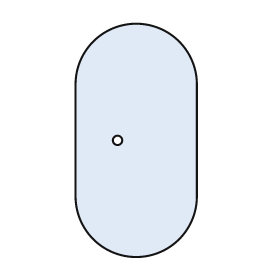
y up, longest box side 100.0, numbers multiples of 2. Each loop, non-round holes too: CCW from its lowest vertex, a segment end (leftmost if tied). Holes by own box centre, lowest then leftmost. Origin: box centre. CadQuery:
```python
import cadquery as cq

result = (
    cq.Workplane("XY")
    .moveTo(-26.0, -24.0)
    .threePointArc((0.0, -50.0), (26.0, -24.0))
    .lineTo(26.0, 24.0)
    .threePointArc((0.0, 50.0), (-26.0, 24.0))
    .close()
    .moveTo(-8.0, 0.0)
    .circle(2.0)
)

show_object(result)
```